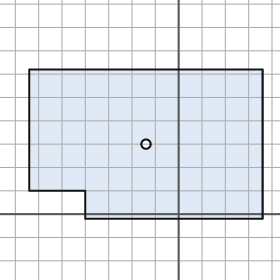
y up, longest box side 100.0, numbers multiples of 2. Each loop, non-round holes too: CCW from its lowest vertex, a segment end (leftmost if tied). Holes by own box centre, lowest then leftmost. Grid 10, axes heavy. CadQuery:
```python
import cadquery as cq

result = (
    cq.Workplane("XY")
    .moveTo(-40.0, -2.0)
    .lineTo(36.0, -2.0)
    .lineTo(36.0, 62.0)
    .lineTo(-64.0, 62.0)
    .lineTo(-64.0, 10.0)
    .lineTo(-40.0, 10.0)
    .close()
    .moveTo(-14.0, 30.0)
    .circle(2.0)
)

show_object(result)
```